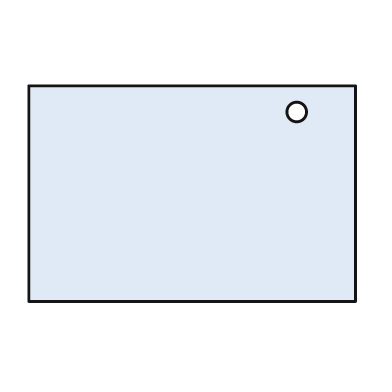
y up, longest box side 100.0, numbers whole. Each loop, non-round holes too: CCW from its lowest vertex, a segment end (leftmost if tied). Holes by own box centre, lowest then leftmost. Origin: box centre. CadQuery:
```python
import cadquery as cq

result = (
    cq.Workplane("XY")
    .moveTo(-50.0, -33.0)
    .lineTo(50.0, -33.0)
    .lineTo(50.0, 33.0)
    .lineTo(-50.0, 33.0)
    .close()
    .moveTo(32.0, 25.0)
    .circle(3.0)
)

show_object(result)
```